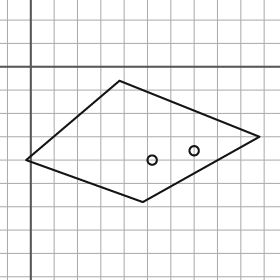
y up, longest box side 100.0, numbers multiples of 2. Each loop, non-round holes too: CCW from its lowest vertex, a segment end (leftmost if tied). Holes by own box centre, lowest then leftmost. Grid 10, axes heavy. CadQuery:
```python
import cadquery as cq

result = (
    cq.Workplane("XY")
    .moveTo(48.0, -58.0)
    .lineTo(98.0, -30.0)
    .lineTo(38.0, -6.0)
    .lineTo(-2.0, -40.0)
    .close()
    .moveTo(52.0, -40.0)
    .circle(2.0)
    .moveTo(70.0, -36.0)
    .circle(2.0)
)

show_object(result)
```